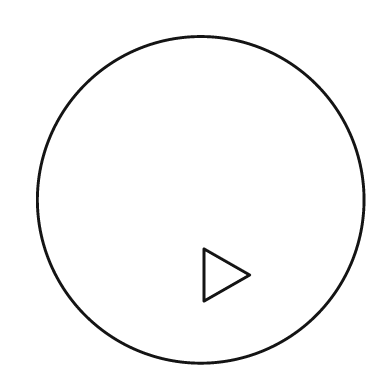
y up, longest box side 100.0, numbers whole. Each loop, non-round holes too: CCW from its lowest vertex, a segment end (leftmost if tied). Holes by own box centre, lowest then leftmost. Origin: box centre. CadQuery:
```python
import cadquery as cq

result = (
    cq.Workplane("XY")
    .moveTo(0.0, 0.0)
    .circle(50.0)
    .moveTo(1.0, -31.0)
    .lineTo(15.0, -23.0)
    .lineTo(1.0, -15.0)
    .close()
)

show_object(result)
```